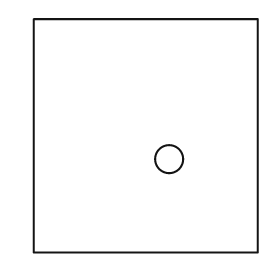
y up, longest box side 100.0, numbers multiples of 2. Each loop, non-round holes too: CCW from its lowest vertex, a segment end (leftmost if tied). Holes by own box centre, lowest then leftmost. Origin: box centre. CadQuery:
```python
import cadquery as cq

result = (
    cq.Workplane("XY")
    .moveTo(-48.0, -50.0)
    .lineTo(48.0, -50.0)
    .lineTo(48.0, 50.0)
    .lineTo(-48.0, 50.0)
    .close()
    .moveTo(10.0, -10.0)
    .circle(6.0)
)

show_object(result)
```